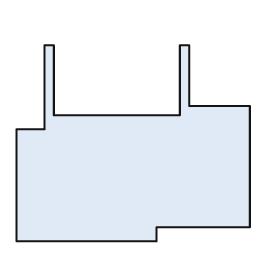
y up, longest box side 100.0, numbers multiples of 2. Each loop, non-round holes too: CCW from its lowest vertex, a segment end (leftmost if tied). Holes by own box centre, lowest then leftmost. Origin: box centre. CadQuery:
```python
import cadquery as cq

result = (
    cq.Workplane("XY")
    .moveTo(-50.0, -42.0)
    .lineTo(10.0, -42.0)
    .lineTo(10.0, -36.0)
    .lineTo(50.0, -36.0)
    .lineTo(50.0, 16.0)
    .lineTo(24.0, 16.0)
    .lineTo(24.0, 42.0)
    .lineTo(20.0, 42.0)
    .lineTo(20.0, 12.0)
    .lineTo(-34.0, 12.0)
    .lineTo(-34.0, 42.0)
    .lineTo(-38.0, 42.0)
    .lineTo(-38.0, 6.0)
    .lineTo(-50.0, 6.0)
    .close()
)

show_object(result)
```